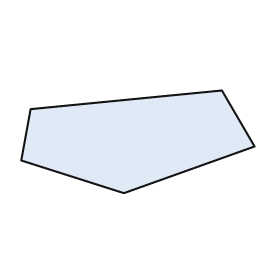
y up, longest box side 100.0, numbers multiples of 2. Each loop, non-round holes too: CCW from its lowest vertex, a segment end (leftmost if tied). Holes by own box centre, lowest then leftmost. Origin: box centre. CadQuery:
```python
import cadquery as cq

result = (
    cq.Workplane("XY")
    .moveTo(-6.0, -22.0)
    .lineTo(50.0, -2.0)
    .lineTo(36.0, 22.0)
    .lineTo(-46.0, 14.0)
    .lineTo(-50.0, -8.0)
    .close()
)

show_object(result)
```